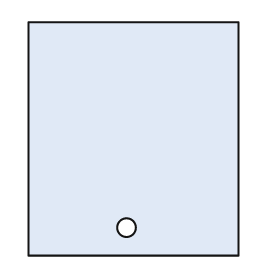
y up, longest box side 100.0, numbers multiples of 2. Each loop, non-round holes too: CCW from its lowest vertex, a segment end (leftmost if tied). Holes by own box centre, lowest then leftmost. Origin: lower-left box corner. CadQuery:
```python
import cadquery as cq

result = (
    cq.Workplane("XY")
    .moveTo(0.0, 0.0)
    .lineTo(90.0, 0.0)
    .lineTo(90.0, 100.0)
    .lineTo(0.0, 100.0)
    .close()
    .moveTo(42.0, 12.0)
    .circle(4.0)
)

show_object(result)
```